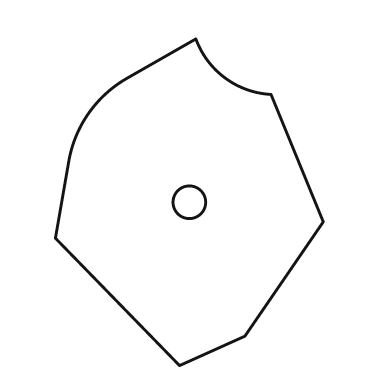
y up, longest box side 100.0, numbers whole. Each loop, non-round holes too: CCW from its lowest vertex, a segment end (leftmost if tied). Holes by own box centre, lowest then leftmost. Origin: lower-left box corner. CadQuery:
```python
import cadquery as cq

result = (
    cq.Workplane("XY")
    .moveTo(38.0, 0.0)
    .lineTo(58.0, 9.0)
    .lineTo(82.0, 44.0)
    .lineTo(66.0, 83.0)
    .threePointArc((52.0, 88.0), (43.0, 100.0))
    .lineTo(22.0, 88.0)
    .threePointArc((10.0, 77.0), (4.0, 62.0))
    .lineTo(0.0, 39.0)
    .close()
    .moveTo(41.0, 50.0)
    .circle(5.0)
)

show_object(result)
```